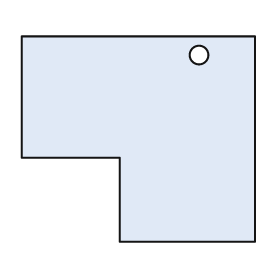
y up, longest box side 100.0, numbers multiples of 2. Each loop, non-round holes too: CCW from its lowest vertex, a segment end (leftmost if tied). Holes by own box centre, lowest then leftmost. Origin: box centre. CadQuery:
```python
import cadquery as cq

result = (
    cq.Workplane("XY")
    .moveTo(-8.0, -44.0)
    .lineTo(50.0, -44.0)
    .lineTo(50.0, 44.0)
    .lineTo(-50.0, 44.0)
    .lineTo(-50.0, -8.0)
    .lineTo(-8.0, -8.0)
    .close()
    .moveTo(26.0, 36.0)
    .circle(4.0)
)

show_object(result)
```